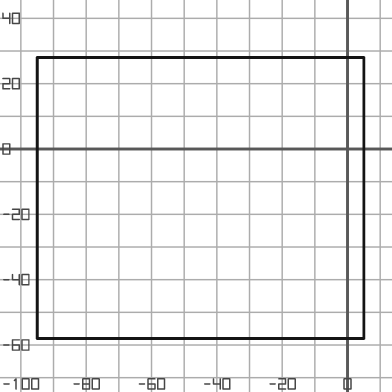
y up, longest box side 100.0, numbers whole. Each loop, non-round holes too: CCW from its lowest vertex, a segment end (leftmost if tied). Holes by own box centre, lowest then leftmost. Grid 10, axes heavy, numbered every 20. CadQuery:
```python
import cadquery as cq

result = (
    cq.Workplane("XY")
    .moveTo(-95.0, -58.0)
    .lineTo(5.0, -58.0)
    .lineTo(5.0, 28.0)
    .lineTo(-95.0, 28.0)
    .close()
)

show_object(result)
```